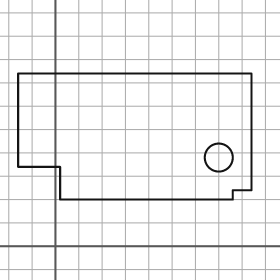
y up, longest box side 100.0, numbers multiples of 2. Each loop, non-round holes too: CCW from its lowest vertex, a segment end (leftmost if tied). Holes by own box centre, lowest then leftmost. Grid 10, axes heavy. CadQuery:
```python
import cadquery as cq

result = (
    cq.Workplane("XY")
    .moveTo(2.0, 20.0)
    .lineTo(76.0, 20.0)
    .lineTo(76.0, 24.0)
    .lineTo(84.0, 24.0)
    .lineTo(84.0, 74.0)
    .lineTo(-16.0, 74.0)
    .lineTo(-16.0, 34.0)
    .lineTo(2.0, 34.0)
    .close()
    .moveTo(70.0, 38.0)
    .circle(6.0)
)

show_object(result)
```